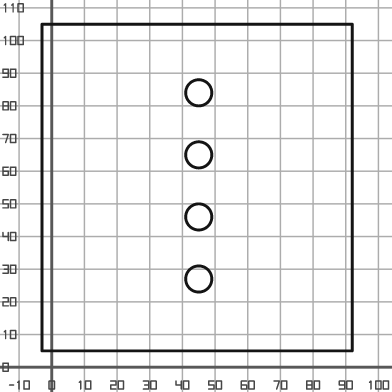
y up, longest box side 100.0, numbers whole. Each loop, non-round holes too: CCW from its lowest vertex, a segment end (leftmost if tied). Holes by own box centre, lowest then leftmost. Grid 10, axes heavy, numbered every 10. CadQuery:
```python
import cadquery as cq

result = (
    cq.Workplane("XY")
    .moveTo(-3.0, 5.0)
    .lineTo(92.0, 5.0)
    .lineTo(92.0, 105.0)
    .lineTo(-3.0, 105.0)
    .close()
    .moveTo(45.0, 27.0)
    .circle(4.0)
    .moveTo(45.0, 46.0)
    .circle(4.0)
    .moveTo(45.0, 65.0)
    .circle(4.0)
    .moveTo(45.0, 84.0)
    .circle(4.0)
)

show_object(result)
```